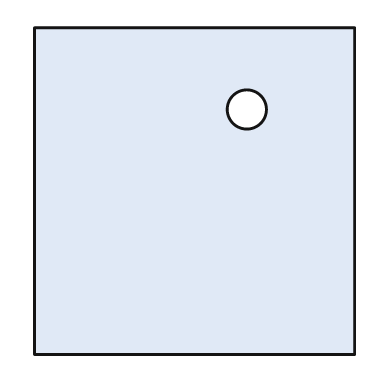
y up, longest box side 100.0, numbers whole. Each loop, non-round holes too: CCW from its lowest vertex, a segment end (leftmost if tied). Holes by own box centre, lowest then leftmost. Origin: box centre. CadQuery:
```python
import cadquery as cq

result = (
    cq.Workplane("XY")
    .moveTo(-49.0, -50.0)
    .lineTo(49.0, -50.0)
    .lineTo(49.0, 50.0)
    .lineTo(-49.0, 50.0)
    .close()
    .moveTo(16.0, 25.0)
    .circle(6.0)
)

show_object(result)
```